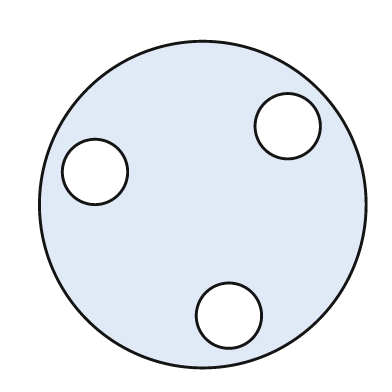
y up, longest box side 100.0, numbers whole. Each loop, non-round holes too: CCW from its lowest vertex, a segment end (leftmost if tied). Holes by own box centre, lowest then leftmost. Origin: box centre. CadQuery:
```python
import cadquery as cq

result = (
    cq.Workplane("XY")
    .moveTo(0.0, 0.0)
    .circle(50.0)
    .moveTo(8.0, -34.0)
    .circle(10.0)
    .moveTo(-33.0, 10.0)
    .circle(10.0)
    .moveTo(26.0, 24.0)
    .circle(10.0)
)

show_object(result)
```